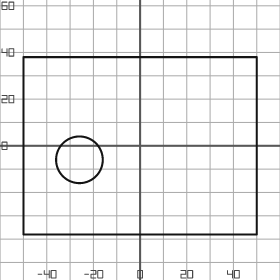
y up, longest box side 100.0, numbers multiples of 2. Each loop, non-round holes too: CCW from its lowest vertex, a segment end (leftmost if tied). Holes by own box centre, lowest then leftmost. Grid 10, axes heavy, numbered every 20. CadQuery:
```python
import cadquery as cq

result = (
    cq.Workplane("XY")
    .moveTo(-50.0, -38.0)
    .lineTo(50.0, -38.0)
    .lineTo(50.0, 38.0)
    .lineTo(-50.0, 38.0)
    .close()
    .moveTo(-26.0, -6.0)
    .circle(10.0)
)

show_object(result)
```